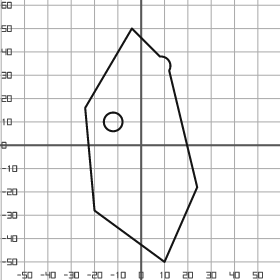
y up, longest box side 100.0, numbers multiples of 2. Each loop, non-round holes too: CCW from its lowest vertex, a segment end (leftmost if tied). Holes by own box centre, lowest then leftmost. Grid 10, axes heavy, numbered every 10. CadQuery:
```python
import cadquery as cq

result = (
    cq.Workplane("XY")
    .moveTo(10.0, -50.0)
    .lineTo(24.0, -18.0)
    .lineTo(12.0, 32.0)
    .threePointArc((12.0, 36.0), (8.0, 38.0))
    .lineTo(-4.0, 50.0)
    .lineTo(-24.0, 16.0)
    .lineTo(-20.0, -28.0)
    .close()
    .moveTo(-12.0, 10.0)
    .circle(4.0)
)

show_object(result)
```